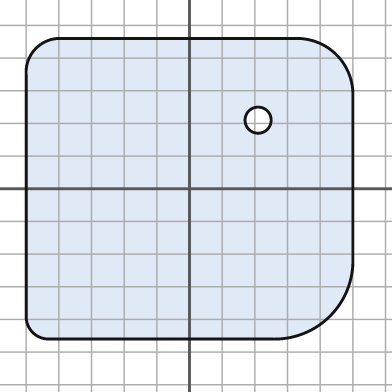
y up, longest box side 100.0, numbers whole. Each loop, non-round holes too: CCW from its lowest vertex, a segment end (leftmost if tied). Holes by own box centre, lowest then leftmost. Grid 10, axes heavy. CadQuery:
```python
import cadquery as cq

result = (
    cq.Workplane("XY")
    .moveTo(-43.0, -46.0)
    .lineTo(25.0, -46.0)
    .threePointArc((43.0, -39.0), (50.0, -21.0))
    .lineTo(50.0, 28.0)
    .threePointArc((45.0, 41.0), (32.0, 46.0))
    .lineTo(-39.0, 46.0)
    .threePointArc((-47.0, 43.0), (-50.0, 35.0))
    .lineTo(-50.0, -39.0)
    .threePointArc((-48.0, -44.0), (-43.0, -46.0))
    .close()
    .moveTo(21.0, 21.0)
    .circle(4.0)
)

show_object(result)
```